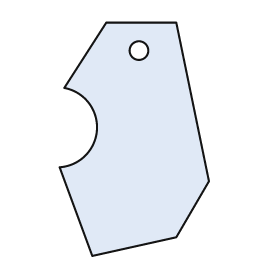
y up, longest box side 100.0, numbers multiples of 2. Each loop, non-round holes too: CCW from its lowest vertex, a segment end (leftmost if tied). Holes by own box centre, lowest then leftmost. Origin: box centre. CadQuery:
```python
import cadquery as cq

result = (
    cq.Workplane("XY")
    .moveTo(-18.0, -50.0)
    .lineTo(18.0, -42.0)
    .lineTo(32.0, -18.0)
    .lineTo(18.0, 50.0)
    .lineTo(-12.0, 50.0)
    .lineTo(-30.0, 22.0)
    .threePointArc((-16.0, 4.0), (-32.0, -12.0))
    .close()
    .moveTo(2.0, 38.0)
    .circle(4.0)
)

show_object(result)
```